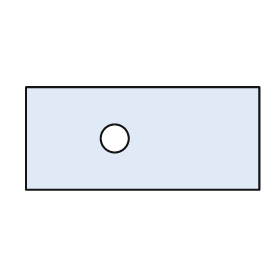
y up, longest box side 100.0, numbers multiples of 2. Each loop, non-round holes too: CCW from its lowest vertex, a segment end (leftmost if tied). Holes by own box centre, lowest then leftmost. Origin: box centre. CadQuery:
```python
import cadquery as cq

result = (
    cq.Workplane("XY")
    .moveTo(-50.0, -22.0)
    .lineTo(50.0, -22.0)
    .lineTo(50.0, 22.0)
    .lineTo(-50.0, 22.0)
    .close()
    .moveTo(-12.0, 0.0)
    .circle(6.0)
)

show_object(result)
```